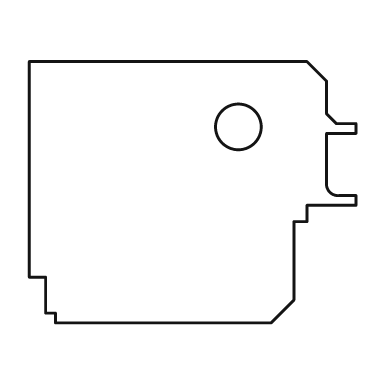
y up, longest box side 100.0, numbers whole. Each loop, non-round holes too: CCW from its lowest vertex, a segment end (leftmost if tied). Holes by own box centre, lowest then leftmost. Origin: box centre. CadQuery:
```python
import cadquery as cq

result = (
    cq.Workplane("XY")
    .moveTo(-42.0, -40.0)
    .lineTo(24.0, -40.0)
    .lineTo(31.0, -33.0)
    .lineTo(31.0, -9.0)
    .lineTo(35.0, -9.0)
    .lineTo(35.0, -4.0)
    .lineTo(50.0, -4.0)
    .lineTo(50.0, -1.0)
    .lineTo(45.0, -1.0)
    .threePointArc((42.0, 0.0), (41.0, 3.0))
    .lineTo(41.0, 18.0)
    .lineTo(50.0, 18.0)
    .lineTo(50.0, 21.0)
    .lineTo(44.0, 21.0)
    .lineTo(41.0, 24.0)
    .lineTo(41.0, 34.0)
    .lineTo(35.0, 40.0)
    .lineTo(-50.0, 40.0)
    .lineTo(-50.0, -26.0)
    .lineTo(-45.0, -26.0)
    .lineTo(-45.0, -37.0)
    .lineTo(-42.0, -37.0)
    .close()
    .moveTo(14.0, 20.0)
    .circle(7.0)
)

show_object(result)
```